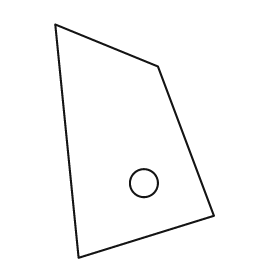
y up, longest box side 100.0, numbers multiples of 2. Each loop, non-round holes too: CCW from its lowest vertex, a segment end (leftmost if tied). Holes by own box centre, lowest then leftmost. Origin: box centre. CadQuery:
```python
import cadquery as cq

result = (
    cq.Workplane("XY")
    .moveTo(-24.0, -50.0)
    .lineTo(34.0, -32.0)
    .lineTo(10.0, 32.0)
    .lineTo(-34.0, 50.0)
    .close()
    .moveTo(4.0, -18.0)
    .circle(6.0)
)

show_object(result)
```